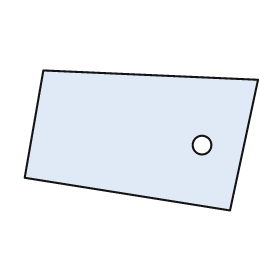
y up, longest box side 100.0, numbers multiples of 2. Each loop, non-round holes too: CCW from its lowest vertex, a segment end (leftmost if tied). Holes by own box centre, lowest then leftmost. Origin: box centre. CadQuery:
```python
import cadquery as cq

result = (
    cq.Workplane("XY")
    .moveTo(38.0, -30.0)
    .lineTo(50.0, 26.0)
    .lineTo(-42.0, 30.0)
    .lineTo(-50.0, -16.0)
    .close()
    .moveTo(26.0, -2.0)
    .circle(4.0)
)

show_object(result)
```